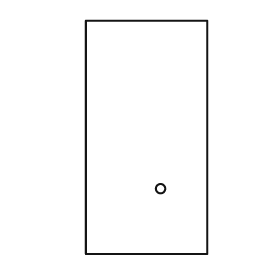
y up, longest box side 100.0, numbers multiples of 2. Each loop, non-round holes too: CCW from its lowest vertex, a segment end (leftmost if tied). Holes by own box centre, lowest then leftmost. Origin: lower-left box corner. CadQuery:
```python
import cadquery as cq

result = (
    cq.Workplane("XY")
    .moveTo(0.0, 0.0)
    .lineTo(52.0, 0.0)
    .lineTo(52.0, 100.0)
    .lineTo(0.0, 100.0)
    .close()
    .moveTo(32.0, 28.0)
    .circle(2.0)
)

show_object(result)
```